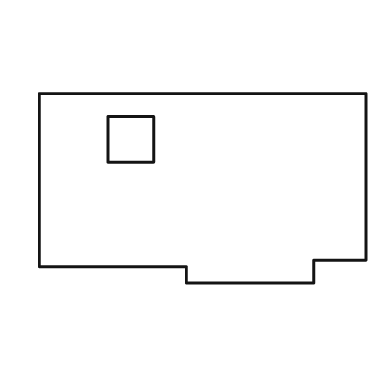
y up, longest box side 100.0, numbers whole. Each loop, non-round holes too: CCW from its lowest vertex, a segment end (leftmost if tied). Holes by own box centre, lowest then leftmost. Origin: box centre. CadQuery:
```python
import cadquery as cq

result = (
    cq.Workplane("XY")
    .moveTo(-5.0, -29.0)
    .lineTo(34.0, -29.0)
    .lineTo(34.0, -22.0)
    .lineTo(50.0, -22.0)
    .lineTo(50.0, 29.0)
    .lineTo(-50.0, 29.0)
    .lineTo(-50.0, -24.0)
    .lineTo(-5.0, -24.0)
    .close()
    .moveTo(-29.0, 8.0)
    .lineTo(-15.0, 8.0)
    .lineTo(-15.0, 22.0)
    .lineTo(-29.0, 22.0)
    .close()
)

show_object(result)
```